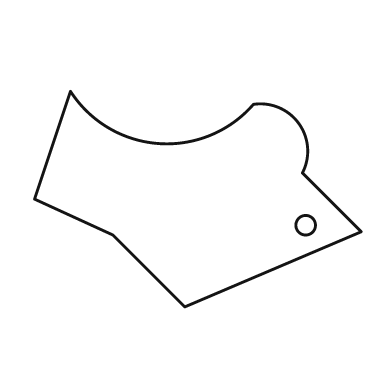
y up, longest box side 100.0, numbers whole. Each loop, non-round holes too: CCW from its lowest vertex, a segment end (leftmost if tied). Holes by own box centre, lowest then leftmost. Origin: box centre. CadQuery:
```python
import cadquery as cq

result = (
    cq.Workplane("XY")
    .moveTo(-4.0, -33.0)
    .lineTo(50.0, -10.0)
    .lineTo(32.0, 8.0)
    .threePointArc((31.0, 23.0), (17.0, 29.0))
    .threePointArc((-12.0, 17.0), (-39.0, 33.0))
    .lineTo(-50.0, 0.0)
    .lineTo(-26.0, -11.0)
    .close()
    .moveTo(33.0, -8.0)
    .circle(3.0)
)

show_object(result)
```